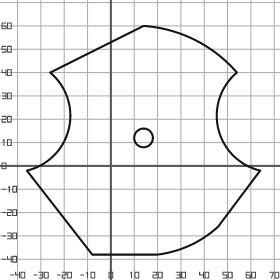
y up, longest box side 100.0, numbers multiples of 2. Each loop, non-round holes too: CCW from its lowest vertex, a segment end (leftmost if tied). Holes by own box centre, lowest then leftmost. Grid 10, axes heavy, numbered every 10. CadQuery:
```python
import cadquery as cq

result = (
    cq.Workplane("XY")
    .moveTo(-8.0, -38.0)
    .lineTo(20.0, -38.0)
    .threePointArc((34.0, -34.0), (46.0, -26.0))
    .lineTo(64.0, -2.0)
    .threePointArc((46.0, 16.0), (54.0, 40.0))
    .threePointArc((36.0, 54.0), (14.0, 60.0))
    .lineTo(-26.0, 40.0)
    .threePointArc((-18.0, 16.0), (-36.0, -2.0))
    .close()
    .moveTo(14.0, 12.0)
    .circle(4.0)
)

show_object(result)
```